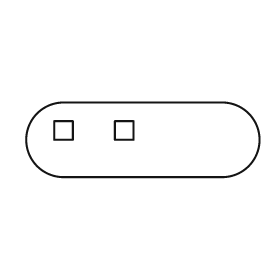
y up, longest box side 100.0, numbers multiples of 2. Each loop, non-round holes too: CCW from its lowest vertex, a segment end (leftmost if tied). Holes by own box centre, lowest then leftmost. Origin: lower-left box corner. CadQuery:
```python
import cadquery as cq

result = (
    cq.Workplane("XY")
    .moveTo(16.0, 0.0)
    .lineTo(84.0, 0.0)
    .threePointArc((100.0, 16.0), (84.0, 32.0))
    .lineTo(16.0, 32.0)
    .threePointArc((0.0, 16.0), (16.0, 0.0))
    .close()
    .moveTo(12.0, 16.0)
    .lineTo(20.0, 16.0)
    .lineTo(20.0, 24.0)
    .lineTo(12.0, 24.0)
    .close()
    .moveTo(38.0, 16.0)
    .lineTo(46.0, 16.0)
    .lineTo(46.0, 24.0)
    .lineTo(38.0, 24.0)
    .close()
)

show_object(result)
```